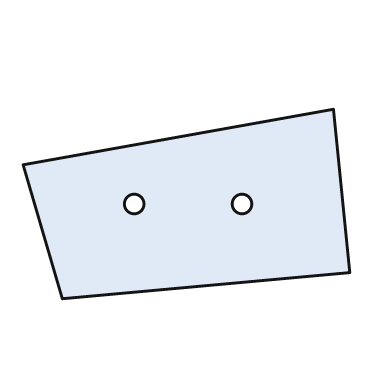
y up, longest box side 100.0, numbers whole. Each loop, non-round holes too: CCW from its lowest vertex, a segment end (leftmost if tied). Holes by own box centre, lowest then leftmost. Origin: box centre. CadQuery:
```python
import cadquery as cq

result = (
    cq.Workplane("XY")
    .moveTo(-38.0, -29.0)
    .lineTo(50.0, -21.0)
    .lineTo(45.0, 29.0)
    .lineTo(-50.0, 12.0)
    .close()
    .moveTo(-16.0, 0.0)
    .circle(3.0)
    .moveTo(17.0, 0.0)
    .circle(3.0)
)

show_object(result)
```